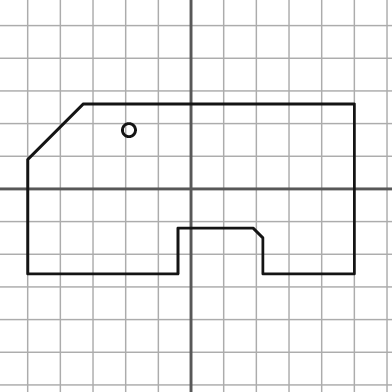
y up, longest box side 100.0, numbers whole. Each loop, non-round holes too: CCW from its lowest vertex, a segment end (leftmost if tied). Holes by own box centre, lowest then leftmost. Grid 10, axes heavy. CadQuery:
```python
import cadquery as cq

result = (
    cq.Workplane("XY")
    .moveTo(-50.0, -26.0)
    .lineTo(-4.0, -26.0)
    .lineTo(-4.0, -12.0)
    .lineTo(19.0, -12.0)
    .lineTo(22.0, -15.0)
    .lineTo(22.0, -26.0)
    .lineTo(50.0, -26.0)
    .lineTo(50.0, 26.0)
    .lineTo(-33.0, 26.0)
    .lineTo(-50.0, 9.0)
    .close()
    .moveTo(-19.0, 18.0)
    .circle(2.0)
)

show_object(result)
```